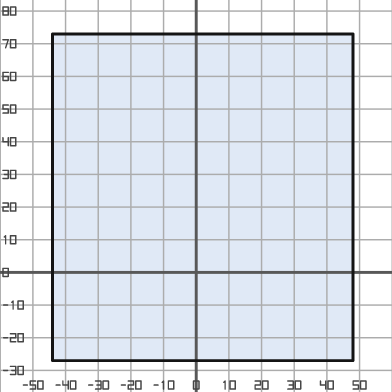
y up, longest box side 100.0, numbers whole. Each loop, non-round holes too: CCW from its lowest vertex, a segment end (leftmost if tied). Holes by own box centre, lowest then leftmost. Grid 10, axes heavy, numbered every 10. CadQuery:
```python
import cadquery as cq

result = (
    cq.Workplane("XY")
    .moveTo(-44.0, -27.0)
    .lineTo(48.0, -27.0)
    .lineTo(48.0, 73.0)
    .lineTo(-44.0, 73.0)
    .close()
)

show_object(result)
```